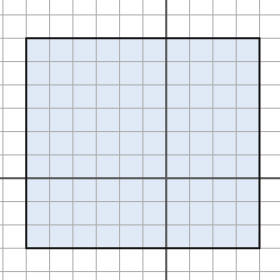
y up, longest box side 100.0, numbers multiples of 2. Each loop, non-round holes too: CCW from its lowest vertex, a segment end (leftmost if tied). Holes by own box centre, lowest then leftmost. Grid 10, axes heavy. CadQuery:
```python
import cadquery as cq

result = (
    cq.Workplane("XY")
    .moveTo(-60.0, -30.0)
    .lineTo(40.0, -30.0)
    .lineTo(40.0, 60.0)
    .lineTo(-60.0, 60.0)
    .close()
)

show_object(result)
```